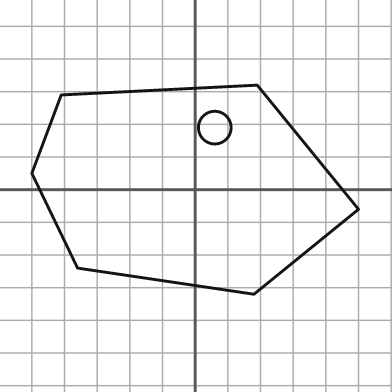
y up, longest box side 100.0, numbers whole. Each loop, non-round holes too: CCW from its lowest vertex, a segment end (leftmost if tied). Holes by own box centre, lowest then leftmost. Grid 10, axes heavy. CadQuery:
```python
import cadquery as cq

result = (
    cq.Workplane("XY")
    .moveTo(18.0, -32.0)
    .lineTo(50.0, -6.0)
    .lineTo(19.0, 32.0)
    .lineTo(-41.0, 29.0)
    .lineTo(-50.0, 5.0)
    .lineTo(-36.0, -24.0)
    .close()
    .moveTo(6.0, 19.0)
    .circle(5.0)
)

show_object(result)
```